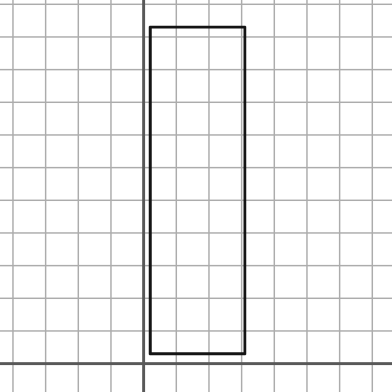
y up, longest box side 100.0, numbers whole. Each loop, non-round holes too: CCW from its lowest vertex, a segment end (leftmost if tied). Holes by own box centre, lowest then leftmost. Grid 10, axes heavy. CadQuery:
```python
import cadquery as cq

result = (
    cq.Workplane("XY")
    .moveTo(2.0, 3.0)
    .lineTo(31.0, 3.0)
    .lineTo(31.0, 103.0)
    .lineTo(2.0, 103.0)
    .close()
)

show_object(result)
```